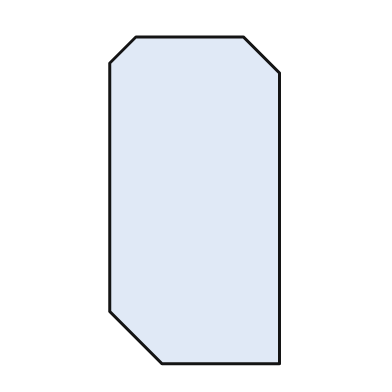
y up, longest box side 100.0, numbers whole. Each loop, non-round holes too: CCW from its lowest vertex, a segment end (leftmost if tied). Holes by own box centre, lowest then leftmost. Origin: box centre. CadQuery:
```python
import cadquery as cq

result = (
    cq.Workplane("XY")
    .moveTo(-10.0, -50.0)
    .lineTo(26.0, -50.0)
    .lineTo(26.0, 39.0)
    .lineTo(15.0, 50.0)
    .lineTo(-18.0, 50.0)
    .lineTo(-26.0, 42.0)
    .lineTo(-26.0, -34.0)
    .close()
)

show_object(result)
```